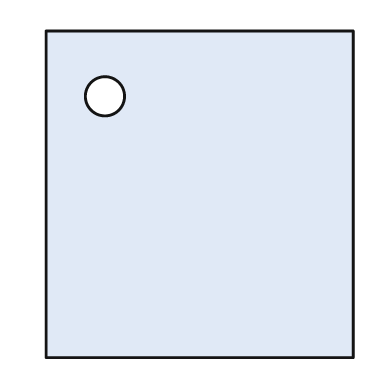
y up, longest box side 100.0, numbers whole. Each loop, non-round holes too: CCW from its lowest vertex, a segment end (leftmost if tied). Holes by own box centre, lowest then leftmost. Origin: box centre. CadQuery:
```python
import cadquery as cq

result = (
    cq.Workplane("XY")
    .moveTo(-47.0, -50.0)
    .lineTo(47.0, -50.0)
    .lineTo(47.0, 50.0)
    .lineTo(-47.0, 50.0)
    .close()
    .moveTo(-29.0, 30.0)
    .circle(6.0)
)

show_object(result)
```